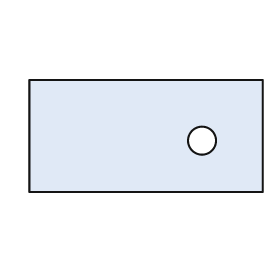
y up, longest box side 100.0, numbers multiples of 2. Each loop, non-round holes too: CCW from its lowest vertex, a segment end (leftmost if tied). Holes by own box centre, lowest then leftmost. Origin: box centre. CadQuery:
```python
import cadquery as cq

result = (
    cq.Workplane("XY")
    .moveTo(-50.0, -24.0)
    .lineTo(50.0, -24.0)
    .lineTo(50.0, 24.0)
    .lineTo(-50.0, 24.0)
    .close()
    .moveTo(24.0, -2.0)
    .circle(6.0)
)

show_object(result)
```